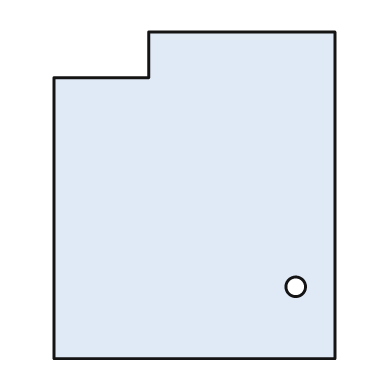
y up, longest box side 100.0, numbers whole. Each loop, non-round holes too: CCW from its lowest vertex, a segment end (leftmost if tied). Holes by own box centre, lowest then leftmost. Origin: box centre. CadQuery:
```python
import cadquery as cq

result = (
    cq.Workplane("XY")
    .moveTo(-43.0, -50.0)
    .lineTo(43.0, -50.0)
    .lineTo(43.0, 50.0)
    .lineTo(-14.0, 50.0)
    .lineTo(-14.0, 36.0)
    .lineTo(-43.0, 36.0)
    .close()
    .moveTo(31.0, -28.0)
    .circle(3.0)
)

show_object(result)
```